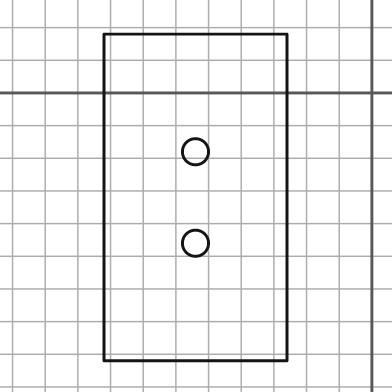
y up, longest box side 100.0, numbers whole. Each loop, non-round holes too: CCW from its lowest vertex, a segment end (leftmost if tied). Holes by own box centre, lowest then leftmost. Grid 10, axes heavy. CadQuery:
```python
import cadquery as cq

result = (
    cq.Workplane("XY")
    .moveTo(-82.0, -82.0)
    .lineTo(-26.0, -82.0)
    .lineTo(-26.0, 18.0)
    .lineTo(-82.0, 18.0)
    .close()
    .moveTo(-54.0, -46.0)
    .circle(4.0)
    .moveTo(-54.0, -18.0)
    .circle(4.0)
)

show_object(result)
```